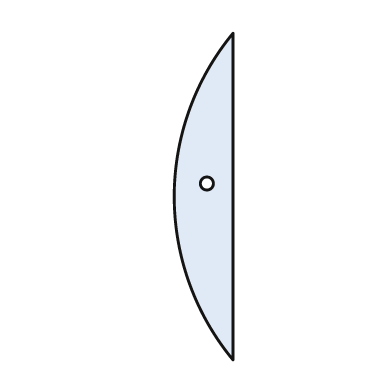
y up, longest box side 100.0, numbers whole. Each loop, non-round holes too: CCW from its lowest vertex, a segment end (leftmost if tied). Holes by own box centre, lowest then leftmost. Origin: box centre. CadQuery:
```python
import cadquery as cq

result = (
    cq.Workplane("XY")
    .moveTo(9.0, -50.0)
    .lineTo(9.0, 50.0)
    .threePointArc((-9.0, 0.0), (9.0, -50.0))
    .close()
    .moveTo(1.0, 4.0)
    .circle(2.0)
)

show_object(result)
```